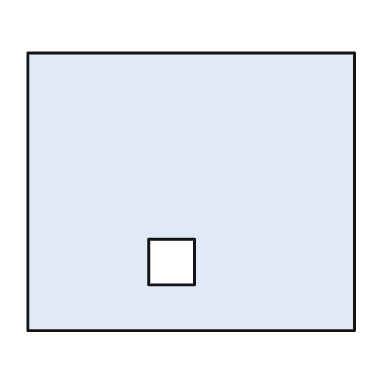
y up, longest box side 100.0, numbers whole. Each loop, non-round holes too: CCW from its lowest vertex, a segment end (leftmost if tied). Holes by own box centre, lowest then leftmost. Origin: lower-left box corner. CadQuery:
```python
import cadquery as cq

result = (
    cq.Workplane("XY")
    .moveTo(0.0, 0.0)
    .lineTo(100.0, 0.0)
    .lineTo(100.0, 85.0)
    .lineTo(0.0, 85.0)
    .close()
    .moveTo(37.0, 14.0)
    .lineTo(51.0, 14.0)
    .lineTo(51.0, 28.0)
    .lineTo(37.0, 28.0)
    .close()
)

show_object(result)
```